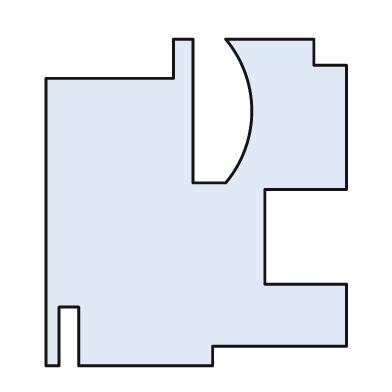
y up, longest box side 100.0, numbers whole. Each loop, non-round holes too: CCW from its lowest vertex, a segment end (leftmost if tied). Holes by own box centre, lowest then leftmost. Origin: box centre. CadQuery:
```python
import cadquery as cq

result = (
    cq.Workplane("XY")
    .moveTo(-46.0, -50.0)
    .lineTo(-42.0, -50.0)
    .lineTo(-42.0, -32.0)
    .lineTo(-36.0, -32.0)
    .lineTo(-36.0, -50.0)
    .lineTo(5.0, -50.0)
    .lineTo(5.0, -44.0)
    .lineTo(46.0, -44.0)
    .lineTo(46.0, -25.0)
    .lineTo(21.0, -25.0)
    .lineTo(21.0, 4.0)
    .lineTo(46.0, 4.0)
    .lineTo(46.0, 42.0)
    .lineTo(36.0, 42.0)
    .lineTo(36.0, 50.0)
    .lineTo(9.0, 50.0)
    .threePointArc((17.0, 28.0), (9.0, 6.0))
    .lineTo(-1.0, 6.0)
    .lineTo(-1.0, 50.0)
    .lineTo(-7.0, 50.0)
    .lineTo(-7.0, 38.0)
    .lineTo(-46.0, 38.0)
    .close()
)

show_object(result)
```